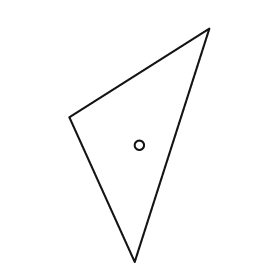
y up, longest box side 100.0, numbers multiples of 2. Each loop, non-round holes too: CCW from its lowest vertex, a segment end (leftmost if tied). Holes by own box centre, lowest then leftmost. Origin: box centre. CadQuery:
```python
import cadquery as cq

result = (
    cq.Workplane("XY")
    .moveTo(-2.0, -50.0)
    .lineTo(30.0, 50.0)
    .lineTo(-30.0, 12.0)
    .close()
    .moveTo(0.0, 0.0)
    .circle(2.0)
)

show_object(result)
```